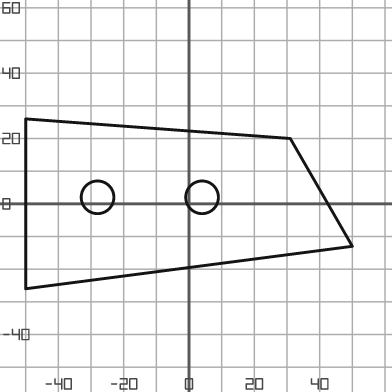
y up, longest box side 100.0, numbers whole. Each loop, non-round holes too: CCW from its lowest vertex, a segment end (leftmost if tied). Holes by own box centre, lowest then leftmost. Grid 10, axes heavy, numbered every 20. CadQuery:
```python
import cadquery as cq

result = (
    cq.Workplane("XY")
    .moveTo(-50.0, -26.0)
    .lineTo(50.0, -13.0)
    .lineTo(31.0, 20.0)
    .lineTo(-50.0, 26.0)
    .close()
    .moveTo(-28.0, 2.0)
    .circle(5.0)
    .moveTo(4.0, 2.0)
    .circle(5.0)
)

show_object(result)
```